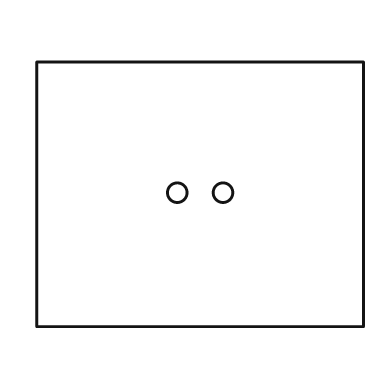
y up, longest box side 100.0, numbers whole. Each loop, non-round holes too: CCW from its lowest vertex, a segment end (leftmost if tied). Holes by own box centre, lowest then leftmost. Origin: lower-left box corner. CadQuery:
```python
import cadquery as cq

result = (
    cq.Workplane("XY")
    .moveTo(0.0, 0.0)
    .lineTo(100.0, 0.0)
    .lineTo(100.0, 81.0)
    .lineTo(0.0, 81.0)
    .close()
    .moveTo(43.0, 41.0)
    .circle(3.0)
    .moveTo(57.0, 41.0)
    .circle(3.0)
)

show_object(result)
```